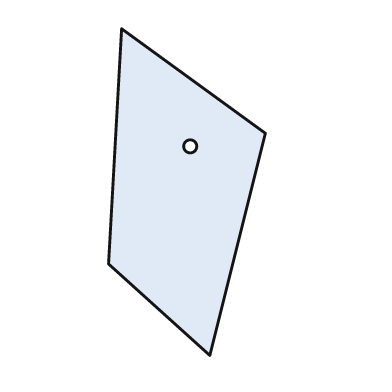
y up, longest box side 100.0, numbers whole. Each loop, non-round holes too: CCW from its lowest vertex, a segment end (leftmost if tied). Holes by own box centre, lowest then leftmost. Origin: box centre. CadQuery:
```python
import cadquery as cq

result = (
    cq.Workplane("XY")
    .moveTo(7.0, -50.0)
    .lineTo(24.0, 18.0)
    .lineTo(-20.0, 50.0)
    .lineTo(-24.0, -22.0)
    .close()
    .moveTo(1.0, 14.0)
    .circle(2.0)
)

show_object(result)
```